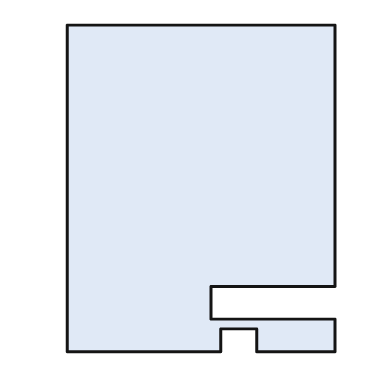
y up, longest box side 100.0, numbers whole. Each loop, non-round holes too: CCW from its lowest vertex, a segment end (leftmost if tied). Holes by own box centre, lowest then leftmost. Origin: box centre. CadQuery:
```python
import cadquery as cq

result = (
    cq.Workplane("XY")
    .moveTo(-41.0, -50.0)
    .lineTo(6.0, -50.0)
    .lineTo(6.0, -43.0)
    .lineTo(17.0, -43.0)
    .lineTo(17.0, -50.0)
    .lineTo(41.0, -50.0)
    .lineTo(41.0, -40.0)
    .lineTo(3.0, -40.0)
    .lineTo(3.0, -30.0)
    .lineTo(41.0, -30.0)
    .lineTo(41.0, 50.0)
    .lineTo(-41.0, 50.0)
    .close()
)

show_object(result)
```